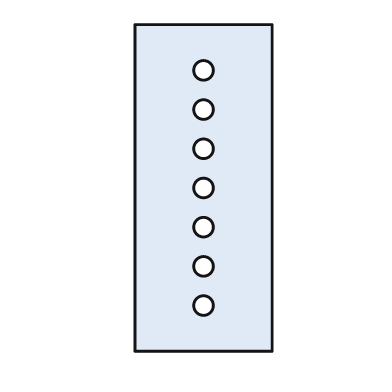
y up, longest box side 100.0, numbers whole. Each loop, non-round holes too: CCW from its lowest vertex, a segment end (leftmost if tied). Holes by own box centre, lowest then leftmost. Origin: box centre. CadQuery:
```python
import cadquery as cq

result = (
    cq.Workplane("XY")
    .moveTo(-21.0, -50.0)
    .lineTo(21.0, -50.0)
    .lineTo(21.0, 50.0)
    .lineTo(-21.0, 50.0)
    .close()
    .moveTo(0.0, -36.0)
    .circle(3.0)
    .moveTo(0.0, -24.0)
    .circle(3.0)
    .moveTo(0.0, -12.0)
    .circle(3.0)
    .moveTo(0.0, 0.0)
    .circle(3.0)
    .moveTo(0.0, 12.0)
    .circle(3.0)
    .moveTo(0.0, 24.0)
    .circle(3.0)
    .moveTo(0.0, 36.0)
    .circle(3.0)
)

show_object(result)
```